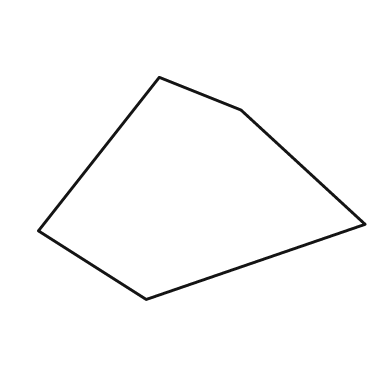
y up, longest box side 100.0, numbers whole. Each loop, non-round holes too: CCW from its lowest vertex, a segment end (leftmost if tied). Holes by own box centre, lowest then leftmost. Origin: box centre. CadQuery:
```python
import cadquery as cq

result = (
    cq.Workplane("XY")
    .moveTo(-17.0, -34.0)
    .lineTo(50.0, -11.0)
    .lineTo(12.0, 24.0)
    .lineTo(-13.0, 34.0)
    .lineTo(-50.0, -13.0)
    .close()
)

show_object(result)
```